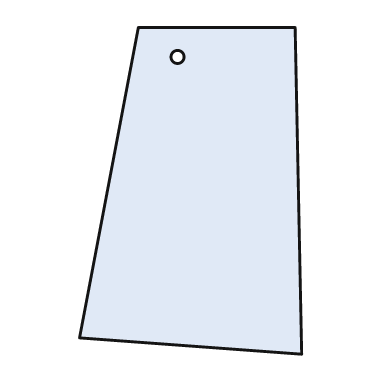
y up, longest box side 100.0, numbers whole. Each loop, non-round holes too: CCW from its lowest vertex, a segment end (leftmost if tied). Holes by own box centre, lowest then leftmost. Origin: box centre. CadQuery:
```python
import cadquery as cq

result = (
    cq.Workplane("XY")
    .moveTo(34.0, -50.0)
    .lineTo(32.0, 50.0)
    .lineTo(-16.0, 50.0)
    .lineTo(-34.0, -45.0)
    .close()
    .moveTo(-4.0, 41.0)
    .circle(2.0)
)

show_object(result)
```